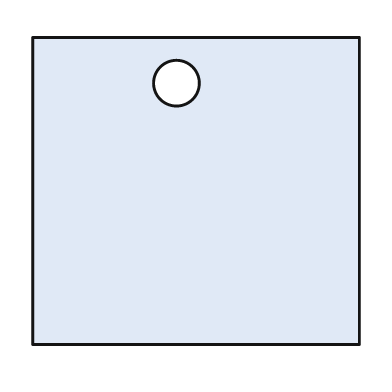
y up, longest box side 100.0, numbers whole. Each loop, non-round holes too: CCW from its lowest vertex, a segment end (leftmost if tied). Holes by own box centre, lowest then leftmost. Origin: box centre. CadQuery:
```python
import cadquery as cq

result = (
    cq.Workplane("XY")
    .moveTo(-50.0, -47.0)
    .lineTo(50.0, -47.0)
    .lineTo(50.0, 47.0)
    .lineTo(-50.0, 47.0)
    .close()
    .moveTo(-6.0, 33.0)
    .circle(7.0)
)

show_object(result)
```